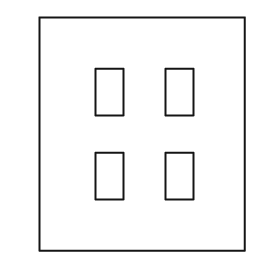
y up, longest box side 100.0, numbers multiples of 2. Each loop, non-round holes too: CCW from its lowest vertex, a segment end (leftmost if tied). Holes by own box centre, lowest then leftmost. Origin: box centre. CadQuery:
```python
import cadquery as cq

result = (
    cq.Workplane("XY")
    .moveTo(-44.0, -50.0)
    .lineTo(44.0, -50.0)
    .lineTo(44.0, 50.0)
    .lineTo(-44.0, 50.0)
    .close()
    .moveTo(-20.0, -28.0)
    .lineTo(-8.0, -28.0)
    .lineTo(-8.0, -8.0)
    .lineTo(-20.0, -8.0)
    .close()
    .moveTo(10.0, -28.0)
    .lineTo(22.0, -28.0)
    .lineTo(22.0, -8.0)
    .lineTo(10.0, -8.0)
    .close()
    .moveTo(-20.0, 8.0)
    .lineTo(-8.0, 8.0)
    .lineTo(-8.0, 28.0)
    .lineTo(-20.0, 28.0)
    .close()
    .moveTo(10.0, 8.0)
    .lineTo(22.0, 8.0)
    .lineTo(22.0, 28.0)
    .lineTo(10.0, 28.0)
    .close()
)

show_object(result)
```